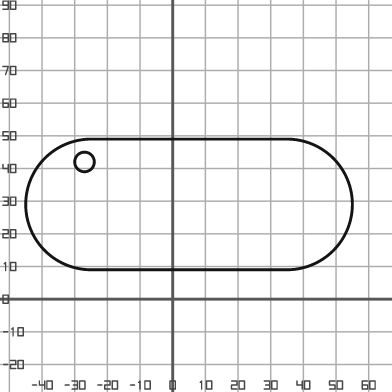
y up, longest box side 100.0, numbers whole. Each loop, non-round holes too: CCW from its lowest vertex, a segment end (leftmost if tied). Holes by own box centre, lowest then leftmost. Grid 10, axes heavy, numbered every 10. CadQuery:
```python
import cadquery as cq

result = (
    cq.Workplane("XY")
    .moveTo(-25.0, 9.0)
    .lineTo(35.0, 9.0)
    .threePointArc((55.0, 29.0), (35.0, 49.0))
    .lineTo(-25.0, 49.0)
    .threePointArc((-45.0, 29.0), (-25.0, 9.0))
    .close()
    .moveTo(-27.0, 42.0)
    .circle(3.0)
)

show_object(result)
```